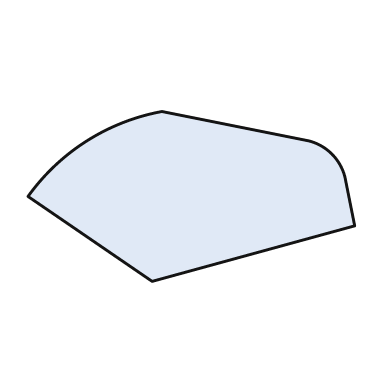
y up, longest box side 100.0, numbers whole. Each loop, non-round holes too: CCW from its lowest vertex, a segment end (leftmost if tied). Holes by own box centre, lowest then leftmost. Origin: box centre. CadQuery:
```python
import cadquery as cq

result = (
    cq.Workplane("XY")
    .moveTo(-12.0, -26.0)
    .lineTo(50.0, -9.0)
    .lineTo(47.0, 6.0)
    .threePointArc((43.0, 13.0), (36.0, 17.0))
    .lineTo(-9.0, 26.0)
    .threePointArc((-32.0, 17.0), (-50.0, 0.0))
    .close()
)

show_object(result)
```